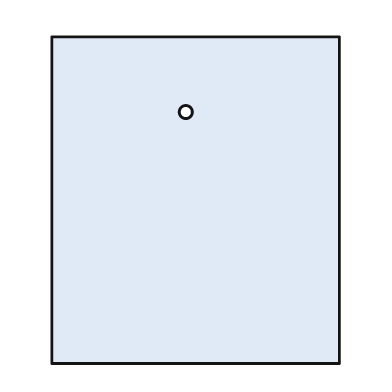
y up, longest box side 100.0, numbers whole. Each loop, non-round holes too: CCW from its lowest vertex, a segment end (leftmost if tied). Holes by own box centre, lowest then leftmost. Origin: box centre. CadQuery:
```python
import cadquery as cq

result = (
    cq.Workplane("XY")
    .moveTo(-44.0, -50.0)
    .lineTo(44.0, -50.0)
    .lineTo(44.0, 50.0)
    .lineTo(-44.0, 50.0)
    .close()
    .moveTo(-3.0, 27.0)
    .circle(2.0)
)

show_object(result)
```